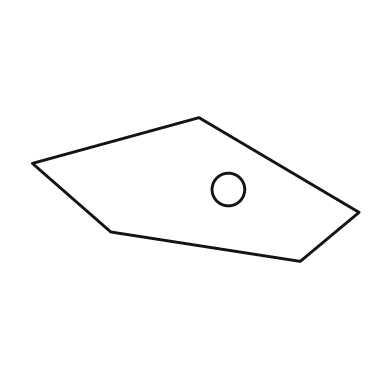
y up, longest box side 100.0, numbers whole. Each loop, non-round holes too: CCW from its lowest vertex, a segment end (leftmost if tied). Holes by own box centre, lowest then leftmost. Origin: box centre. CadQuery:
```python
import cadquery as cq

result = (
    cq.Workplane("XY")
    .moveTo(32.0, -22.0)
    .lineTo(50.0, -7.0)
    .lineTo(1.0, 22.0)
    .lineTo(-50.0, 8.0)
    .lineTo(-26.0, -13.0)
    .close()
    .moveTo(10.0, 0.0)
    .circle(5.0)
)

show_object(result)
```